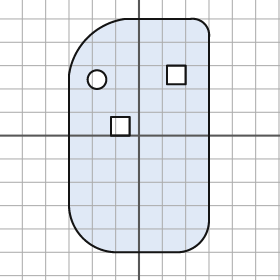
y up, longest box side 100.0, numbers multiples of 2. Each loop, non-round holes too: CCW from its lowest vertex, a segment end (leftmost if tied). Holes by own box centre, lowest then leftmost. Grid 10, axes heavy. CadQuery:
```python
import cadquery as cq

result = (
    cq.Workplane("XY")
    .moveTo(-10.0, -50.0)
    .lineTo(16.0, -50.0)
    .threePointArc((26.0, -46.0), (30.0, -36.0))
    .lineTo(30.0, 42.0)
    .threePointArc((28.0, 48.0), (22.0, 50.0))
    .lineTo(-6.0, 50.0)
    .threePointArc((-22.0, 42.0), (-30.0, 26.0))
    .lineTo(-30.0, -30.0)
    .threePointArc((-24.0, -44.0), (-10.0, -50.0))
    .close()
    .moveTo(-12.0, 0.0)
    .lineTo(-4.0, 0.0)
    .lineTo(-4.0, 8.0)
    .lineTo(-12.0, 8.0)
    .close()
    .moveTo(-18.0, 24.0)
    .circle(4.0)
    .moveTo(12.0, 22.0)
    .lineTo(20.0, 22.0)
    .lineTo(20.0, 30.0)
    .lineTo(12.0, 30.0)
    .close()
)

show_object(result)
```